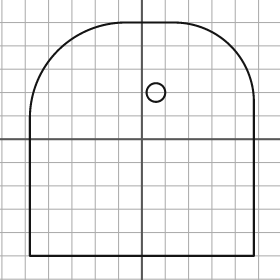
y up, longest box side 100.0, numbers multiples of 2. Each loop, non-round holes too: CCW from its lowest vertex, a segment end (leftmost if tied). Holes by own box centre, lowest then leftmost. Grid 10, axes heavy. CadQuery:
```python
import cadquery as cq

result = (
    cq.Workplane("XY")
    .moveTo(-48.0, -50.0)
    .lineTo(48.0, -50.0)
    .lineTo(48.0, 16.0)
    .threePointArc((38.0, 40.0), (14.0, 50.0))
    .lineTo(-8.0, 50.0)
    .threePointArc((-36.0, 38.0), (-48.0, 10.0))
    .close()
    .moveTo(6.0, 20.0)
    .circle(4.0)
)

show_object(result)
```